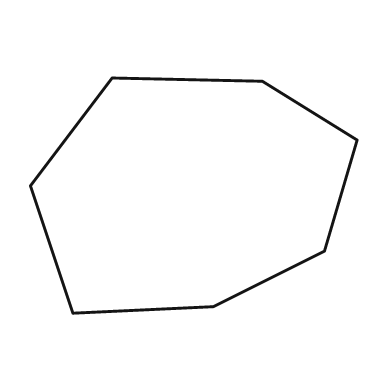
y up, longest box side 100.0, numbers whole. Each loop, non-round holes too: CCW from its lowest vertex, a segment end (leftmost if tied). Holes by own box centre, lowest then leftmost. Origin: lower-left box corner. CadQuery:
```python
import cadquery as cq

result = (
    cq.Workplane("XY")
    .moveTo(13.0, 0.0)
    .lineTo(56.0, 2.0)
    .lineTo(90.0, 19.0)
    .lineTo(100.0, 53.0)
    .lineTo(71.0, 71.0)
    .lineTo(25.0, 72.0)
    .lineTo(0.0, 39.0)
    .close()
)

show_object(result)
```